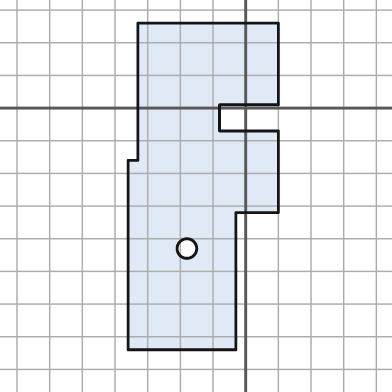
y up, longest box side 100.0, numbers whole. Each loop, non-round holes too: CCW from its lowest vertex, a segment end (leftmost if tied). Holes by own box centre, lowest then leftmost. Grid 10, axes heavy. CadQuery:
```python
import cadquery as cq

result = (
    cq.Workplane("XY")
    .moveTo(-36.0, -74.0)
    .lineTo(-3.0, -74.0)
    .lineTo(-3.0, -32.0)
    .lineTo(10.0, -32.0)
    .lineTo(10.0, -7.0)
    .lineTo(-8.0, -7.0)
    .lineTo(-8.0, 1.0)
    .lineTo(10.0, 1.0)
    .lineTo(10.0, 26.0)
    .lineTo(-33.0, 26.0)
    .lineTo(-33.0, -16.0)
    .lineTo(-36.0, -16.0)
    .close()
    .moveTo(-18.0, -43.0)
    .circle(3.0)
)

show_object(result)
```